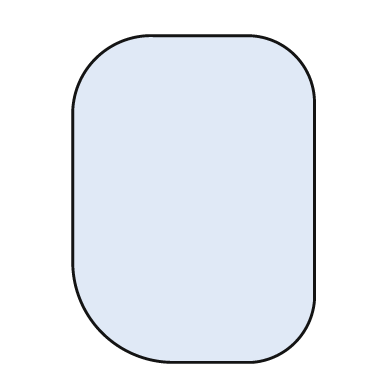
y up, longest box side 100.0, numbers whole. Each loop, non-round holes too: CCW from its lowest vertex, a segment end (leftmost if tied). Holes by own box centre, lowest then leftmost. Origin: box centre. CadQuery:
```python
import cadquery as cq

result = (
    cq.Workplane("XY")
    .moveTo(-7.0, -50.0)
    .lineTo(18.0, -50.0)
    .threePointArc((31.0, -44.0), (37.0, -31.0))
    .lineTo(37.0, 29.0)
    .threePointArc((31.0, 44.0), (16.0, 50.0))
    .lineTo(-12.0, 50.0)
    .threePointArc((-30.0, 43.0), (-37.0, 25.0))
    .lineTo(-37.0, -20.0)
    .threePointArc((-28.0, -41.0), (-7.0, -50.0))
    .close()
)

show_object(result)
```